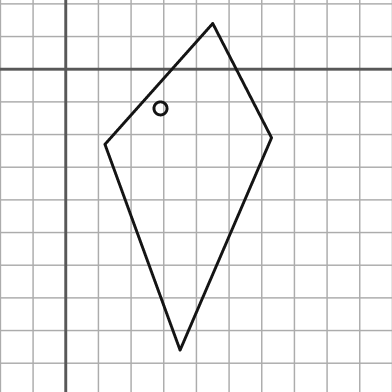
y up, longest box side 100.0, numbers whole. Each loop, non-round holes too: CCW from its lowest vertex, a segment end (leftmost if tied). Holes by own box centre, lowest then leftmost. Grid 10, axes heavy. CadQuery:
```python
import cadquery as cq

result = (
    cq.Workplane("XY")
    .moveTo(35.0, -86.0)
    .lineTo(63.0, -21.0)
    .lineTo(45.0, 14.0)
    .lineTo(12.0, -23.0)
    .close()
    .moveTo(29.0, -12.0)
    .circle(2.0)
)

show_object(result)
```